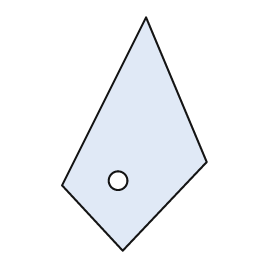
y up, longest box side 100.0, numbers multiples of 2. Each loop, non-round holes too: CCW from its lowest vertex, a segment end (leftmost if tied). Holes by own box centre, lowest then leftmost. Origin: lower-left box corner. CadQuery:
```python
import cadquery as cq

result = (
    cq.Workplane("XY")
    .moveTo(26.0, 0.0)
    .lineTo(62.0, 38.0)
    .lineTo(36.0, 100.0)
    .lineTo(0.0, 28.0)
    .close()
    .moveTo(24.0, 30.0)
    .circle(4.0)
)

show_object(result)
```